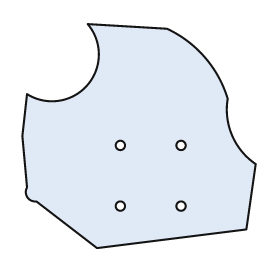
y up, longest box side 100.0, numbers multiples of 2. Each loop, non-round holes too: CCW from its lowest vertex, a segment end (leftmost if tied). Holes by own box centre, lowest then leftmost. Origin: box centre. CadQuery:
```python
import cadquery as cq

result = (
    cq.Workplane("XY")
    .moveTo(-18.0, -48.0)
    .lineTo(46.0, -40.0)
    .lineTo(50.0, -12.0)
    .threePointArc((40.0, 0.0), (38.0, 16.0))
    .threePointArc((28.0, 34.0), (12.0, 46.0))
    .lineTo(-22.0, 48.0)
    .threePointArc((-22.0, 22.0), (-48.0, 18.0))
    .lineTo(-50.0, 0.0)
    .lineTo(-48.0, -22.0)
    .threePointArc((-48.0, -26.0), (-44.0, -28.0))
    .close()
    .moveTo(-8.0, -30.0)
    .circle(2.0)
    .moveTo(18.0, -30.0)
    .circle(2.0)
    .moveTo(-8.0, -4.0)
    .circle(2.0)
    .moveTo(18.0, -4.0)
    .circle(2.0)
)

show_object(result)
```